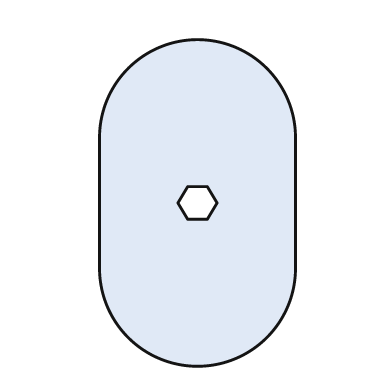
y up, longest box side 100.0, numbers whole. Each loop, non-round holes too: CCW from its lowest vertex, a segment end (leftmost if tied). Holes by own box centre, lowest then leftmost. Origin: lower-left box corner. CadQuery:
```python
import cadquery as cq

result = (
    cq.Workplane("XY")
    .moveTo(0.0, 30.0)
    .threePointArc((30.0, 0.0), (60.0, 30.0))
    .lineTo(60.0, 70.0)
    .threePointArc((30.0, 100.0), (0.0, 70.0))
    .close()
    .moveTo(27.0, 45.0)
    .lineTo(33.0, 45.0)
    .lineTo(36.0, 50.0)
    .lineTo(33.0, 55.0)
    .lineTo(27.0, 55.0)
    .lineTo(24.0, 50.0)
    .close()
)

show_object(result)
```